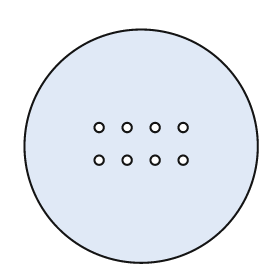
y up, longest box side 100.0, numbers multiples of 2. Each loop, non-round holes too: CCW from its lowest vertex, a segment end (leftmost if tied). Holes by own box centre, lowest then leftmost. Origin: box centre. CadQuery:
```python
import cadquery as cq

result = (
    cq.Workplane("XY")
    .moveTo(0.0, 0.0)
    .circle(50.0)
    .moveTo(-18.0, -6.0)
    .circle(2.0)
    .moveTo(-6.0, -6.0)
    .circle(2.0)
    .moveTo(6.0, -6.0)
    .circle(2.0)
    .moveTo(18.0, -6.0)
    .circle(2.0)
    .moveTo(-18.0, 8.0)
    .circle(2.0)
    .moveTo(-6.0, 8.0)
    .circle(2.0)
    .moveTo(6.0, 8.0)
    .circle(2.0)
    .moveTo(18.0, 8.0)
    .circle(2.0)
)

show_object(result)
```